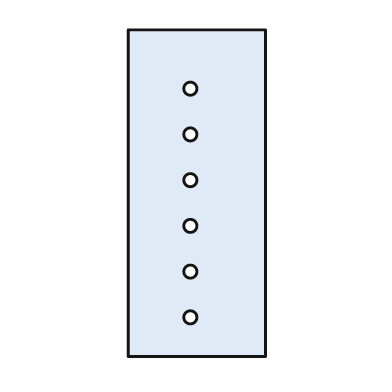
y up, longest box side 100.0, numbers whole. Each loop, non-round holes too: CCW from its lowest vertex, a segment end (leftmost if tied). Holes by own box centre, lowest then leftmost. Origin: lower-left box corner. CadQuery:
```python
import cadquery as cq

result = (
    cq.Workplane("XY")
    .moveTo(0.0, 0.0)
    .lineTo(42.0, 0.0)
    .lineTo(42.0, 100.0)
    .lineTo(0.0, 100.0)
    .close()
    .moveTo(19.0, 12.0)
    .circle(2.0)
    .moveTo(19.0, 26.0)
    .circle(2.0)
    .moveTo(19.0, 40.0)
    .circle(2.0)
    .moveTo(19.0, 54.0)
    .circle(2.0)
    .moveTo(19.0, 68.0)
    .circle(2.0)
    .moveTo(19.0, 82.0)
    .circle(2.0)
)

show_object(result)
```